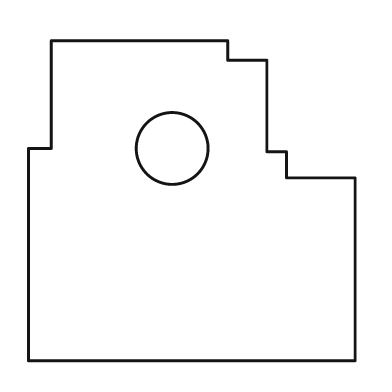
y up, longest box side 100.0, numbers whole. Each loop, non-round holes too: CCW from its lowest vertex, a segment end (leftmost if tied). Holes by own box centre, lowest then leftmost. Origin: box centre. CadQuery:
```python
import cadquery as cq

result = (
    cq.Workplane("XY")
    .moveTo(-50.0, -49.0)
    .lineTo(50.0, -49.0)
    .lineTo(50.0, 7.0)
    .lineTo(29.0, 7.0)
    .lineTo(29.0, 15.0)
    .lineTo(23.0, 15.0)
    .lineTo(23.0, 43.0)
    .lineTo(11.0, 43.0)
    .lineTo(11.0, 49.0)
    .lineTo(-43.0, 49.0)
    .lineTo(-43.0, 16.0)
    .lineTo(-50.0, 16.0)
    .close()
    .moveTo(-6.0, 16.0)
    .circle(11.0)
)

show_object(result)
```